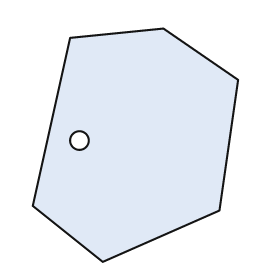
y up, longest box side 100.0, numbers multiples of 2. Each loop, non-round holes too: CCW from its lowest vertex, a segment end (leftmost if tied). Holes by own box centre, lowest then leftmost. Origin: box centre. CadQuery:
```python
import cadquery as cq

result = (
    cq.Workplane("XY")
    .moveTo(-14.0, -50.0)
    .lineTo(36.0, -28.0)
    .lineTo(44.0, 28.0)
    .lineTo(12.0, 50.0)
    .lineTo(-28.0, 46.0)
    .lineTo(-44.0, -26.0)
    .close()
    .moveTo(-24.0, 2.0)
    .circle(4.0)
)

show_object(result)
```